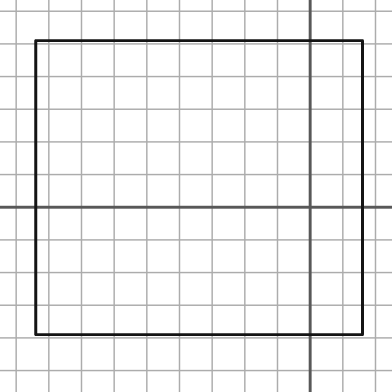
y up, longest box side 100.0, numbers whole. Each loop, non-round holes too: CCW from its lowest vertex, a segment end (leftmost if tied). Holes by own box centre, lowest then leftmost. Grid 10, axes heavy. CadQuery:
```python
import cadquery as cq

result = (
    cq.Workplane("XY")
    .moveTo(-84.0, -39.0)
    .lineTo(16.0, -39.0)
    .lineTo(16.0, 51.0)
    .lineTo(-84.0, 51.0)
    .close()
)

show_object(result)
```